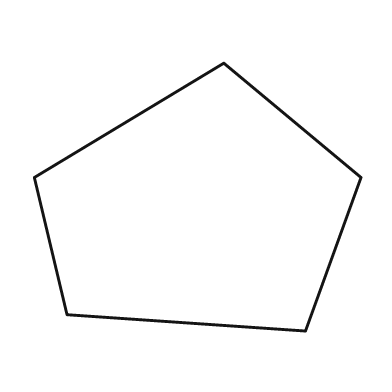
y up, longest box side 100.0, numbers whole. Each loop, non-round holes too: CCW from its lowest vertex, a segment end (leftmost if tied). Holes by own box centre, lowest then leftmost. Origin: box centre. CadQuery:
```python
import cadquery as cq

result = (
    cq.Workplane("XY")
    .moveTo(33.0, -41.0)
    .lineTo(50.0, 6.0)
    .lineTo(8.0, 41.0)
    .lineTo(-50.0, 6.0)
    .lineTo(-40.0, -36.0)
    .close()
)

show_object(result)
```